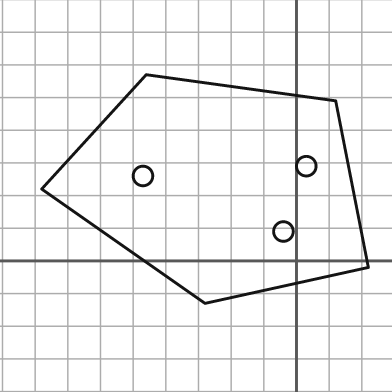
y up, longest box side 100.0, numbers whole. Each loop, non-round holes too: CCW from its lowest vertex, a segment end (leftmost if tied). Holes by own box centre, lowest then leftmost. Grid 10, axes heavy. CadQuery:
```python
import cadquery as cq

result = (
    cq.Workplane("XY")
    .moveTo(-28.0, -13.0)
    .lineTo(22.0, -2.0)
    .lineTo(12.0, 49.0)
    .lineTo(-46.0, 57.0)
    .lineTo(-78.0, 22.0)
    .close()
    .moveTo(-4.0, 9.0)
    .circle(3.0)
    .moveTo(-47.0, 26.0)
    .circle(3.0)
    .moveTo(3.0, 29.0)
    .circle(3.0)
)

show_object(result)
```